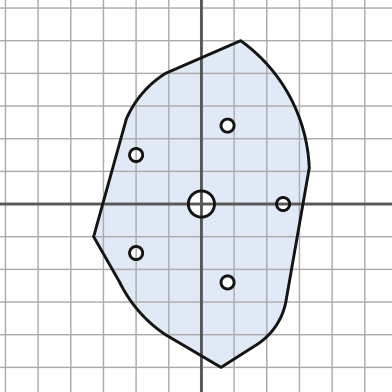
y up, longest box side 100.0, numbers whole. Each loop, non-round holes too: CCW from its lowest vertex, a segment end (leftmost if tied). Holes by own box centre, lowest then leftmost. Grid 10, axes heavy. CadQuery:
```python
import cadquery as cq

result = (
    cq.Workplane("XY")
    .moveTo(6.0, -50.0)
    .lineTo(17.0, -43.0)
    .threePointArc((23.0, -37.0), (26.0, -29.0))
    .lineTo(33.0, 11.0)
    .threePointArc((27.0, 33.0), (12.0, 50.0))
    .lineTo(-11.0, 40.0)
    .threePointArc((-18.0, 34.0), (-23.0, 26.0))
    .lineTo(-33.0, -10.0)
    .lineTo(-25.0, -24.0)
    .threePointArc((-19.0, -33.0), (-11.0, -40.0))
    .close()
    .moveTo(8.0, -24.0)
    .circle(2.0)
    .moveTo(-20.0, -15.0)
    .circle(2.0)
    .moveTo(0.0, 0.0)
    .circle(4.0)
    .moveTo(25.0, 0.0)
    .circle(2.0)
    .moveTo(-20.0, 15.0)
    .circle(2.0)
    .moveTo(8.0, 24.0)
    .circle(2.0)
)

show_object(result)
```